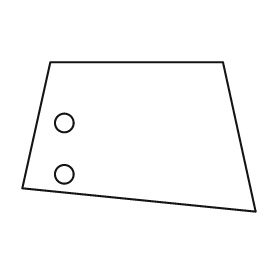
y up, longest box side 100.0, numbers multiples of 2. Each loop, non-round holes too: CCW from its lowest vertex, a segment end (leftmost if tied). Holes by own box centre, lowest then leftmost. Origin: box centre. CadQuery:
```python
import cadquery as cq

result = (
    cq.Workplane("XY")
    .moveTo(50.0, -32.0)
    .lineTo(36.0, 32.0)
    .lineTo(-38.0, 32.0)
    .lineTo(-50.0, -22.0)
    .close()
    .moveTo(-32.0, -16.0)
    .circle(4.0)
    .moveTo(-32.0, 6.0)
    .circle(4.0)
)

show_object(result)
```